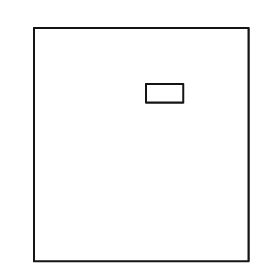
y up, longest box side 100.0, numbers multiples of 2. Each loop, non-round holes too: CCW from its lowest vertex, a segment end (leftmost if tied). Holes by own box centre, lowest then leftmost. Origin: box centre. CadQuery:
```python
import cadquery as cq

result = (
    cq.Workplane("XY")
    .moveTo(-46.0, -50.0)
    .lineTo(46.0, -50.0)
    .lineTo(46.0, 50.0)
    .lineTo(-46.0, 50.0)
    .close()
    .moveTo(2.0, 18.0)
    .lineTo(18.0, 18.0)
    .lineTo(18.0, 26.0)
    .lineTo(2.0, 26.0)
    .close()
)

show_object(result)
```